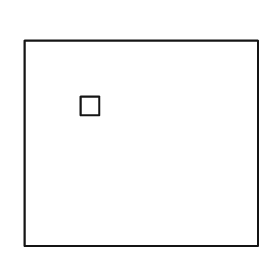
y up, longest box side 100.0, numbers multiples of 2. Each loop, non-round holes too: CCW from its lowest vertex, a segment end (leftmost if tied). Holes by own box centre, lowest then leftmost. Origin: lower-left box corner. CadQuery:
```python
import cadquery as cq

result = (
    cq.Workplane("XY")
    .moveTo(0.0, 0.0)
    .lineTo(100.0, 0.0)
    .lineTo(100.0, 88.0)
    .lineTo(0.0, 88.0)
    .close()
    .moveTo(24.0, 56.0)
    .lineTo(32.0, 56.0)
    .lineTo(32.0, 64.0)
    .lineTo(24.0, 64.0)
    .close()
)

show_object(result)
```